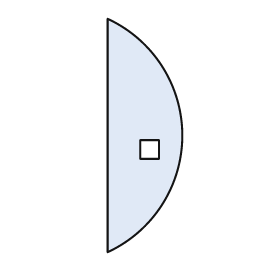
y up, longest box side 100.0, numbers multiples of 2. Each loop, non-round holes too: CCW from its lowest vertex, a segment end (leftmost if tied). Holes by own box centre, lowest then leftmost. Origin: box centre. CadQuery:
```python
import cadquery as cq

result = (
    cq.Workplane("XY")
    .moveTo(-16.0, -50.0)
    .threePointArc((16.0, 0.0), (-16.0, 50.0))
    .close()
    .moveTo(-2.0, -10.0)
    .lineTo(6.0, -10.0)
    .lineTo(6.0, -2.0)
    .lineTo(-2.0, -2.0)
    .close()
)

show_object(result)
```